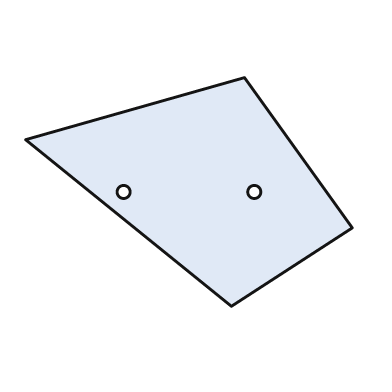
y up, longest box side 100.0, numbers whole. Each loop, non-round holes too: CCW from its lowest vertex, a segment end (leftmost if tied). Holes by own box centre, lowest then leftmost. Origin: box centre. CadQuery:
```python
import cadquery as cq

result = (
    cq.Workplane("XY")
    .moveTo(13.0, -35.0)
    .lineTo(50.0, -11.0)
    .lineTo(17.0, 35.0)
    .lineTo(-50.0, 16.0)
    .close()
    .moveTo(-20.0, 0.0)
    .circle(2.0)
    .moveTo(20.0, 0.0)
    .circle(2.0)
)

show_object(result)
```